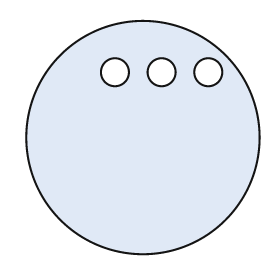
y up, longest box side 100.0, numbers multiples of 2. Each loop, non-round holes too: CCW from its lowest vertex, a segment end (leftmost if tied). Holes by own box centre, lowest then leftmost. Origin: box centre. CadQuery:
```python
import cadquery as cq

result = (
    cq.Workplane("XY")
    .moveTo(0.0, 0.0)
    .circle(50.0)
    .moveTo(-12.0, 28.0)
    .circle(6.0)
    .moveTo(8.0, 28.0)
    .circle(6.0)
    .moveTo(28.0, 28.0)
    .circle(6.0)
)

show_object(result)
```